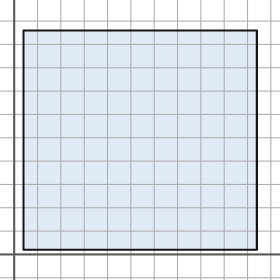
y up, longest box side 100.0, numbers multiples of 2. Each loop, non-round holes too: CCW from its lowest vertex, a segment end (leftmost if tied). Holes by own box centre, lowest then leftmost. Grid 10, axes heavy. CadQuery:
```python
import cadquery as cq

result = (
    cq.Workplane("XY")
    .moveTo(4.0, 2.0)
    .lineTo(104.0, 2.0)
    .lineTo(104.0, 96.0)
    .lineTo(4.0, 96.0)
    .close()
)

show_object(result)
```